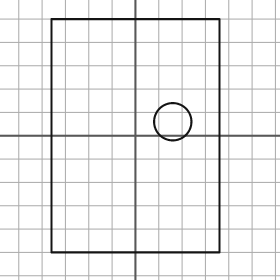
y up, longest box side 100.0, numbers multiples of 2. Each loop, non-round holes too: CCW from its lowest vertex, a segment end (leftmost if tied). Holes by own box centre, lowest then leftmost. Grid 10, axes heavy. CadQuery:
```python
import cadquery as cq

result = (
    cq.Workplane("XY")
    .moveTo(-36.0, -50.0)
    .lineTo(36.0, -50.0)
    .lineTo(36.0, 50.0)
    .lineTo(-36.0, 50.0)
    .close()
    .moveTo(16.0, 6.0)
    .circle(8.0)
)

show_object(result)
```